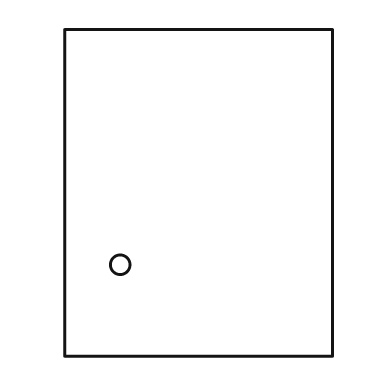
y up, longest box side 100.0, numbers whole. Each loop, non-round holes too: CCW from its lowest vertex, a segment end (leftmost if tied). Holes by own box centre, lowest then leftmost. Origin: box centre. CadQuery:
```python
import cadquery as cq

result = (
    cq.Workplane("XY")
    .moveTo(-41.0, -50.0)
    .lineTo(41.0, -50.0)
    .lineTo(41.0, 50.0)
    .lineTo(-41.0, 50.0)
    .close()
    .moveTo(-24.0, -22.0)
    .circle(3.0)
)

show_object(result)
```